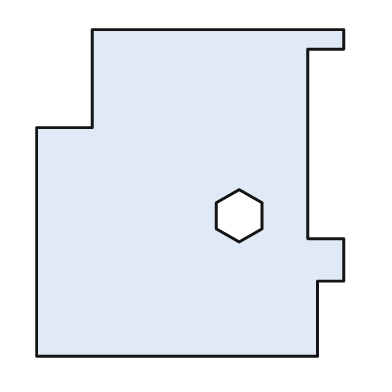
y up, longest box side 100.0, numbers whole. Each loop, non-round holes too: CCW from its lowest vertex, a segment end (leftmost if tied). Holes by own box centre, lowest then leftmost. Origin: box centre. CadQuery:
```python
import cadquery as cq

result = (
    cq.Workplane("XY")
    .moveTo(-47.0, -50.0)
    .lineTo(39.0, -50.0)
    .lineTo(39.0, -27.0)
    .lineTo(47.0, -27.0)
    .lineTo(47.0, -14.0)
    .lineTo(36.0, -14.0)
    .lineTo(36.0, 44.0)
    .lineTo(47.0, 44.0)
    .lineTo(47.0, 50.0)
    .lineTo(-30.0, 50.0)
    .lineTo(-30.0, 20.0)
    .lineTo(-47.0, 20.0)
    .close()
    .moveTo(15.0, -15.0)
    .lineTo(22.0, -11.0)
    .lineTo(22.0, -3.0)
    .lineTo(15.0, 1.0)
    .lineTo(8.0, -3.0)
    .lineTo(8.0, -11.0)
    .close()
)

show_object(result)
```